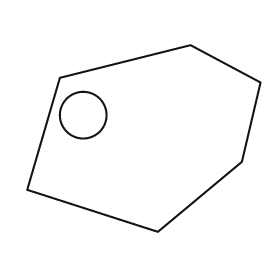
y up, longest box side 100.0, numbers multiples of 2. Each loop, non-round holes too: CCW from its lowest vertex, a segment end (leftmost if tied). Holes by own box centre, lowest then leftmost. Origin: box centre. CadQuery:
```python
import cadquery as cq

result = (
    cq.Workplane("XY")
    .moveTo(6.0, -40.0)
    .lineTo(42.0, -10.0)
    .lineTo(50.0, 24.0)
    .lineTo(20.0, 40.0)
    .lineTo(-36.0, 26.0)
    .lineTo(-50.0, -22.0)
    .close()
    .moveTo(-26.0, 10.0)
    .circle(10.0)
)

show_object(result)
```